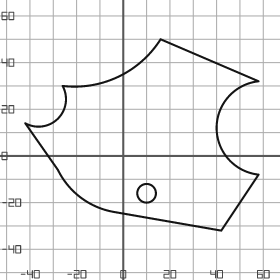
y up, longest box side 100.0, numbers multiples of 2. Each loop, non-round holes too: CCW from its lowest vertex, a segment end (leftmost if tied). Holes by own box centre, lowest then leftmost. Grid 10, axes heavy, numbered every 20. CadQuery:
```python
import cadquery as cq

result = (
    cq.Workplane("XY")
    .moveTo(42.0, -32.0)
    .lineTo(58.0, -8.0)
    .threePointArc((40.0, 12.0), (58.0, 32.0))
    .lineTo(16.0, 50.0)
    .threePointArc((-2.0, 34.0), (-26.0, 30.0))
    .threePointArc((-28.0, 16.0), (-42.0, 14.0))
    .lineTo(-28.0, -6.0)
    .threePointArc((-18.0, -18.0), (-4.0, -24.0))
    .close()
    .moveTo(10.0, -16.0)
    .circle(4.0)
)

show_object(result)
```